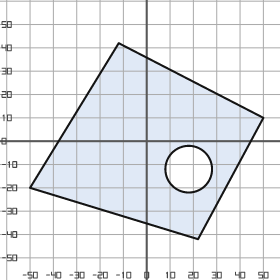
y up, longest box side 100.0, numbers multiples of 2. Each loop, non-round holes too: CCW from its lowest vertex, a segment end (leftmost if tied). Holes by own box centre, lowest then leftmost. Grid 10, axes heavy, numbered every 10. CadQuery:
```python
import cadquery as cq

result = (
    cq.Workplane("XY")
    .moveTo(22.0, -42.0)
    .lineTo(50.0, 10.0)
    .lineTo(-12.0, 42.0)
    .lineTo(-50.0, -20.0)
    .close()
    .moveTo(18.0, -12.0)
    .circle(10.0)
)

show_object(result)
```